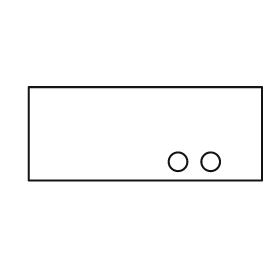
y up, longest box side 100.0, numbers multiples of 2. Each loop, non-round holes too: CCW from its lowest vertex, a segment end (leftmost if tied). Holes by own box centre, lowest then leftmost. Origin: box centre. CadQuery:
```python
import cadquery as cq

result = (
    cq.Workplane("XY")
    .moveTo(-50.0, -20.0)
    .lineTo(50.0, -20.0)
    .lineTo(50.0, 20.0)
    .lineTo(-50.0, 20.0)
    .close()
    .moveTo(14.0, -12.0)
    .circle(4.0)
    .moveTo(28.0, -12.0)
    .circle(4.0)
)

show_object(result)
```